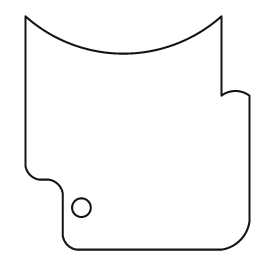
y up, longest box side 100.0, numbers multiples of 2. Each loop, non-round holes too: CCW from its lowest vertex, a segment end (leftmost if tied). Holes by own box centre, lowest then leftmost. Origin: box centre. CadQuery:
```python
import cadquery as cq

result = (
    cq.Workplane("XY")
    .moveTo(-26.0, -50.0)
    .lineTo(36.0, -50.0)
    .threePointArc((44.0, -46.0), (48.0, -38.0))
    .lineTo(48.0, 16.0)
    .threePointArc((42.0, 18.0), (36.0, 16.0))
    .lineTo(36.0, 50.0)
    .threePointArc((-6.0, 34.0), (-48.0, 50.0))
    .lineTo(-48.0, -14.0)
    .threePointArc((-46.0, -18.0), (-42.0, -20.0))
    .lineTo(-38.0, -20.0)
    .threePointArc((-34.0, -22.0), (-32.0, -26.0))
    .lineTo(-32.0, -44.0)
    .threePointArc((-30.0, -48.0), (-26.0, -50.0))
    .close()
    .moveTo(-24.0, -32.0)
    .circle(4.0)
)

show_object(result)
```